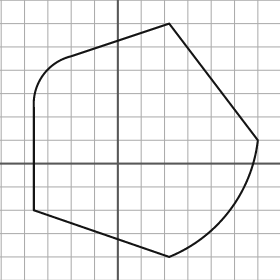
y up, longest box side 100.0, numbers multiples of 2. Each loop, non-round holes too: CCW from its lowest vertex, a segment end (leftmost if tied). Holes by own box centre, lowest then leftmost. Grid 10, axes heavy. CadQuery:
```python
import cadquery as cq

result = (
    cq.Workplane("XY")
    .moveTo(22.0, -40.0)
    .threePointArc((48.0, -20.0), (60.0, 10.0))
    .lineTo(22.0, 60.0)
    .lineTo(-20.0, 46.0)
    .threePointArc((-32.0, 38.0), (-36.0, 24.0))
    .lineTo(-36.0, -20.0)
    .close()
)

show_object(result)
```